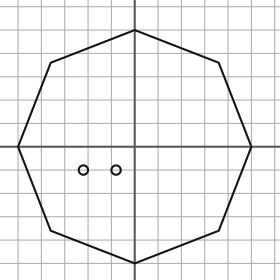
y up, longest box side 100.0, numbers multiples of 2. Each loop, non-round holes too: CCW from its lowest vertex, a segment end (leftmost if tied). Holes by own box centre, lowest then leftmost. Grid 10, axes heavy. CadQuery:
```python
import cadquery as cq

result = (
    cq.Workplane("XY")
    .moveTo(0.0, -50.0)
    .lineTo(36.0, -36.0)
    .lineTo(50.0, 0.0)
    .lineTo(36.0, 36.0)
    .lineTo(0.0, 50.0)
    .lineTo(-36.0, 36.0)
    .lineTo(-50.0, 0.0)
    .lineTo(-36.0, -36.0)
    .close()
    .moveTo(-22.0, -10.0)
    .circle(2.0)
    .moveTo(-8.0, -10.0)
    .circle(2.0)
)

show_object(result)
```